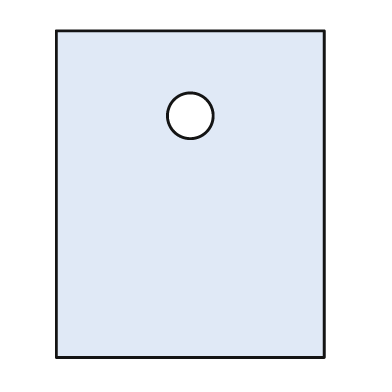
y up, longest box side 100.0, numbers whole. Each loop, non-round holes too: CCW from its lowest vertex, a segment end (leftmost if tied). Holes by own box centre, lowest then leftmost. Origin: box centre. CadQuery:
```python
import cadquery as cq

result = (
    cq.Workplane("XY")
    .moveTo(-41.0, -50.0)
    .lineTo(41.0, -50.0)
    .lineTo(41.0, 50.0)
    .lineTo(-41.0, 50.0)
    .close()
    .moveTo(0.0, 24.0)
    .circle(7.0)
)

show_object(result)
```